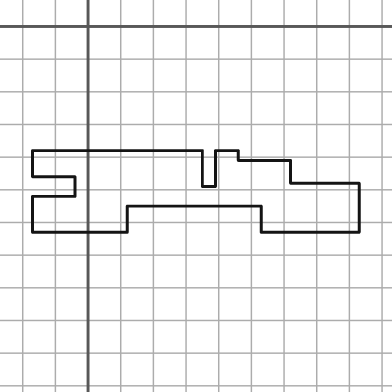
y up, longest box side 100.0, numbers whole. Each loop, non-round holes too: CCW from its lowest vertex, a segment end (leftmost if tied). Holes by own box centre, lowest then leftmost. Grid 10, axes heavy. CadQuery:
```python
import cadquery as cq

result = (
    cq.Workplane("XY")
    .moveTo(-17.0, -63.0)
    .lineTo(12.0, -63.0)
    .lineTo(12.0, -55.0)
    .lineTo(53.0, -55.0)
    .lineTo(53.0, -63.0)
    .lineTo(83.0, -63.0)
    .lineTo(83.0, -48.0)
    .lineTo(62.0, -48.0)
    .lineTo(62.0, -41.0)
    .lineTo(46.0, -41.0)
    .lineTo(46.0, -38.0)
    .lineTo(39.0, -38.0)
    .lineTo(39.0, -49.0)
    .lineTo(35.0, -49.0)
    .lineTo(35.0, -38.0)
    .lineTo(-17.0, -38.0)
    .lineTo(-17.0, -46.0)
    .lineTo(-4.0, -46.0)
    .lineTo(-4.0, -52.0)
    .lineTo(-17.0, -52.0)
    .close()
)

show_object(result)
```